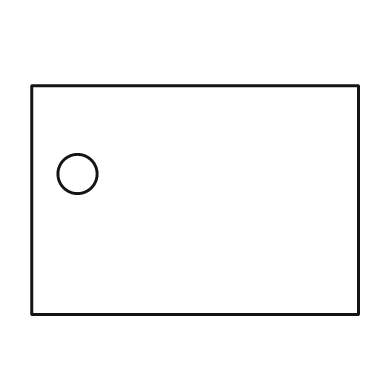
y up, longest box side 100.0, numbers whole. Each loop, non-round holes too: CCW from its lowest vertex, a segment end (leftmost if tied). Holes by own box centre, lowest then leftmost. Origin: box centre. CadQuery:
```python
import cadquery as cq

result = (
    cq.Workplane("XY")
    .moveTo(-50.0, -35.0)
    .lineTo(50.0, -35.0)
    .lineTo(50.0, 35.0)
    .lineTo(-50.0, 35.0)
    .close()
    .moveTo(-36.0, 8.0)
    .circle(6.0)
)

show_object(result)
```